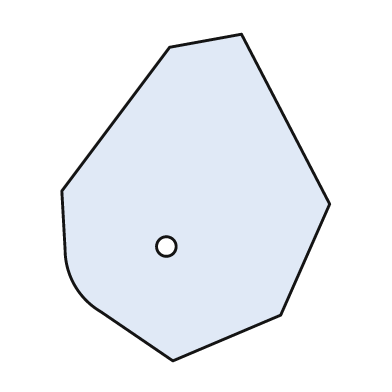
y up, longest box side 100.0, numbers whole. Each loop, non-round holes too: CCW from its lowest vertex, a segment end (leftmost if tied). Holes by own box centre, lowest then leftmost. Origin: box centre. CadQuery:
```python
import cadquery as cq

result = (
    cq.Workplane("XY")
    .moveTo(-7.0, -50.0)
    .lineTo(26.0, -36.0)
    .lineTo(41.0, -2.0)
    .lineTo(14.0, 50.0)
    .lineTo(-8.0, 46.0)
    .lineTo(-41.0, 2.0)
    .lineTo(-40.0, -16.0)
    .threePointArc((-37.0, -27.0), (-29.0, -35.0))
    .close()
    .moveTo(-9.0, -15.0)
    .circle(3.0)
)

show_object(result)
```